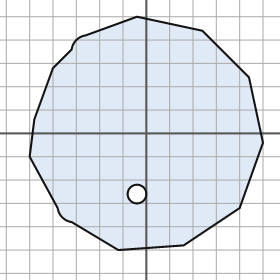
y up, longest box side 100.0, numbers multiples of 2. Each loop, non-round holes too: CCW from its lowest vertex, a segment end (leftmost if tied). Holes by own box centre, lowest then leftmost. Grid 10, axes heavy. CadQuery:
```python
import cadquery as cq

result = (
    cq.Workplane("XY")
    .moveTo(-12.0, -50.0)
    .lineTo(16.0, -48.0)
    .lineTo(40.0, -32.0)
    .lineTo(50.0, -4.0)
    .lineTo(44.0, 24.0)
    .lineTo(24.0, 44.0)
    .lineTo(-4.0, 50.0)
    .lineTo(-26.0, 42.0)
    .threePointArc((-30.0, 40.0), (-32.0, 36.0))
    .lineTo(-40.0, 28.0)
    .lineTo(-48.0, 6.0)
    .lineTo(-50.0, -10.0)
    .lineTo(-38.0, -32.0)
    .threePointArc((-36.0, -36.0), (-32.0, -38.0))
    .close()
    .moveTo(-4.0, -26.0)
    .circle(4.0)
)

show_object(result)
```